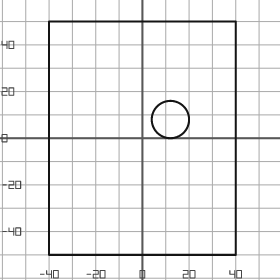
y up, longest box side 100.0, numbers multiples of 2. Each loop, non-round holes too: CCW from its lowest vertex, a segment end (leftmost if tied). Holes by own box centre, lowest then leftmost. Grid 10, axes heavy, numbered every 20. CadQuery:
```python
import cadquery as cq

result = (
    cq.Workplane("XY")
    .moveTo(-40.0, -50.0)
    .lineTo(40.0, -50.0)
    .lineTo(40.0, 50.0)
    .lineTo(-40.0, 50.0)
    .close()
    .moveTo(12.0, 8.0)
    .circle(8.0)
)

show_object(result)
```